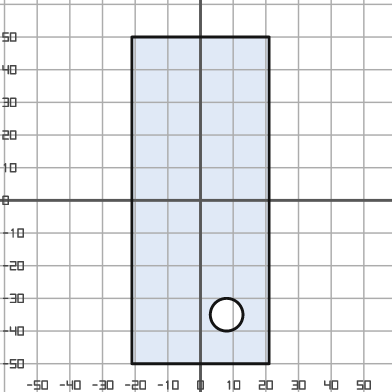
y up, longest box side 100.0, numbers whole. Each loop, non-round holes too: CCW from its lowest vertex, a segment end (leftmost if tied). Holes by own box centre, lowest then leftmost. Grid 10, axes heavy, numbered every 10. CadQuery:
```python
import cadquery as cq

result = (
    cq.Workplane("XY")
    .moveTo(-21.0, -50.0)
    .lineTo(21.0, -50.0)
    .lineTo(21.0, 50.0)
    .lineTo(-21.0, 50.0)
    .close()
    .moveTo(8.0, -35.0)
    .circle(5.0)
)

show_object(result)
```